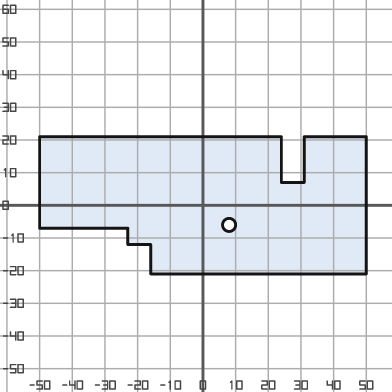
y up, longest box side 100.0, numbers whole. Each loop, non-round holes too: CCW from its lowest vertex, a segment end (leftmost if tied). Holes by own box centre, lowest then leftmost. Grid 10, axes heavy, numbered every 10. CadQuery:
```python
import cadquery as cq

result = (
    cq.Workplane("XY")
    .moveTo(-16.0, -21.0)
    .lineTo(50.0, -21.0)
    .lineTo(50.0, 21.0)
    .lineTo(31.0, 21.0)
    .lineTo(31.0, 7.0)
    .lineTo(24.0, 7.0)
    .lineTo(24.0, 21.0)
    .lineTo(-50.0, 21.0)
    .lineTo(-50.0, -7.0)
    .lineTo(-23.0, -7.0)
    .lineTo(-23.0, -12.0)
    .lineTo(-16.0, -12.0)
    .close()
    .moveTo(8.0, -6.0)
    .circle(2.0)
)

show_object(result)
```